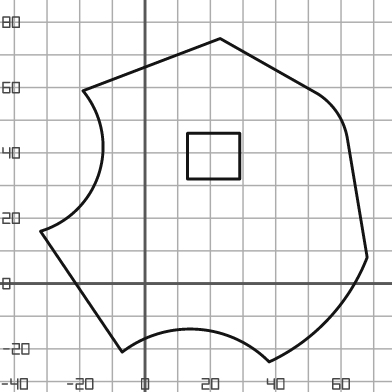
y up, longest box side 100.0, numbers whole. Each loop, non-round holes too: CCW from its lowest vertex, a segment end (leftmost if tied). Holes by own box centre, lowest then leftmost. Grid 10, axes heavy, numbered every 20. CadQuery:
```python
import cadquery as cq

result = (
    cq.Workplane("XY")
    .moveTo(38.0, -24.0)
    .threePointArc((56.0, -11.0), (68.0, 8.0))
    .lineTo(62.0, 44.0)
    .threePointArc((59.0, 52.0), (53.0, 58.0))
    .lineTo(23.0, 75.0)
    .lineTo(-19.0, 59.0)
    .threePointArc((-14.0, 34.0), (-32.0, 16.0))
    .lineTo(-7.0, -21.0)
    .threePointArc((16.0, -14.0), (38.0, -24.0))
    .close()
    .moveTo(13.0, 32.0)
    .lineTo(29.0, 32.0)
    .lineTo(29.0, 46.0)
    .lineTo(13.0, 46.0)
    .close()
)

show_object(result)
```